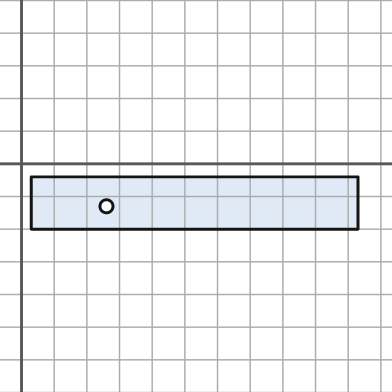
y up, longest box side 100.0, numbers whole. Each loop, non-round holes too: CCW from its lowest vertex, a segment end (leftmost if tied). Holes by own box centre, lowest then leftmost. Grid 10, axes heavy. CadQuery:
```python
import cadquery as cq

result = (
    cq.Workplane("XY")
    .moveTo(3.0, -20.0)
    .lineTo(103.0, -20.0)
    .lineTo(103.0, -4.0)
    .lineTo(3.0, -4.0)
    .close()
    .moveTo(26.0, -13.0)
    .circle(2.0)
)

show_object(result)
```